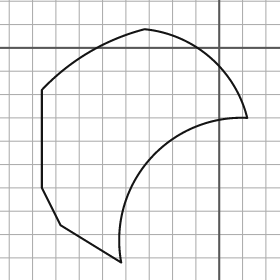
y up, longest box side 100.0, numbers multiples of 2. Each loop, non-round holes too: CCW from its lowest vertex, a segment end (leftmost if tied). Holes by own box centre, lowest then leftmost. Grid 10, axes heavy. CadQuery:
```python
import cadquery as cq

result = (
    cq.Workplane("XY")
    .moveTo(-42.0, -92.0)
    .threePointArc((-30.0, -48.0), (12.0, -30.0))
    .threePointArc((-4.0, -4.0), (-32.0, 8.0))
    .threePointArc((-56.0, -2.0), (-76.0, -18.0))
    .lineTo(-76.0, -60.0)
    .lineTo(-68.0, -76.0)
    .close()
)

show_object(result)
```